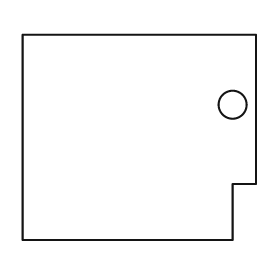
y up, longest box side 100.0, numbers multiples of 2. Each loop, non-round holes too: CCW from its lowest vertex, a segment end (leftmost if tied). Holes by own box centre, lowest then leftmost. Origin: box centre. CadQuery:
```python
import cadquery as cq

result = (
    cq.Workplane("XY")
    .moveTo(-50.0, -44.0)
    .lineTo(40.0, -44.0)
    .lineTo(40.0, -20.0)
    .lineTo(50.0, -20.0)
    .lineTo(50.0, 44.0)
    .lineTo(-50.0, 44.0)
    .close()
    .moveTo(40.0, 14.0)
    .circle(6.0)
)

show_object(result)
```